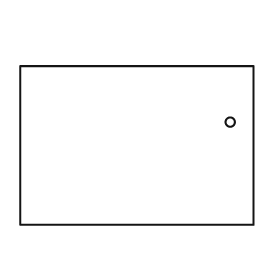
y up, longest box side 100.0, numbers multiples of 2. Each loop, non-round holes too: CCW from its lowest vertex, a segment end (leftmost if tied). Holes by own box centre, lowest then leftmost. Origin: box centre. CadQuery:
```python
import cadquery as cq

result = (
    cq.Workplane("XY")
    .moveTo(-50.0, -34.0)
    .lineTo(50.0, -34.0)
    .lineTo(50.0, 34.0)
    .lineTo(-50.0, 34.0)
    .close()
    .moveTo(40.0, 10.0)
    .circle(2.0)
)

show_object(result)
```